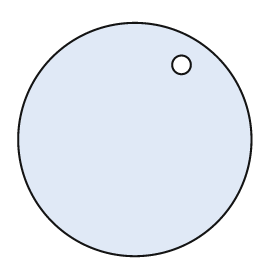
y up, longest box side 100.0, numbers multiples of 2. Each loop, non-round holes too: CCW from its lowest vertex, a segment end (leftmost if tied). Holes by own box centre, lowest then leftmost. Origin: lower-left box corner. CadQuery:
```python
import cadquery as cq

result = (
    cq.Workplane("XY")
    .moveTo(50.0, 50.0)
    .circle(50.0)
    .moveTo(70.0, 82.0)
    .circle(4.0)
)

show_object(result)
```